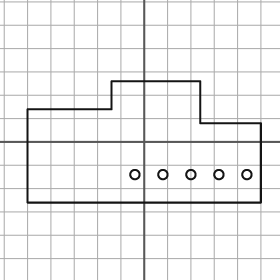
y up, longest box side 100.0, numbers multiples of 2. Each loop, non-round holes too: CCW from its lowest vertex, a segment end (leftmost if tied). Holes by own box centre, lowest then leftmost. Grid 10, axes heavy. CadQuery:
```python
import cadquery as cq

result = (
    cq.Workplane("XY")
    .moveTo(-50.0, -26.0)
    .lineTo(50.0, -26.0)
    .lineTo(50.0, 8.0)
    .lineTo(24.0, 8.0)
    .lineTo(24.0, 26.0)
    .lineTo(-14.0, 26.0)
    .lineTo(-14.0, 14.0)
    .lineTo(-50.0, 14.0)
    .close()
    .moveTo(-4.0, -14.0)
    .circle(2.0)
    .moveTo(8.0, -14.0)
    .circle(2.0)
    .moveTo(20.0, -14.0)
    .circle(2.0)
    .moveTo(32.0, -14.0)
    .circle(2.0)
    .moveTo(44.0, -14.0)
    .circle(2.0)
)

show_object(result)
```